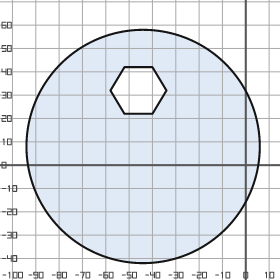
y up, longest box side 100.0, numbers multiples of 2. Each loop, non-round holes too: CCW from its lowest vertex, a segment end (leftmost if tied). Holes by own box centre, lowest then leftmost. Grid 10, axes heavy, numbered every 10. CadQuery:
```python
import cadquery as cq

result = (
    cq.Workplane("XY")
    .moveTo(-44.0, 8.0)
    .circle(50.0)
    .moveTo(-52.0, 22.0)
    .lineTo(-40.0, 22.0)
    .lineTo(-34.0, 32.0)
    .lineTo(-40.0, 42.0)
    .lineTo(-52.0, 42.0)
    .lineTo(-58.0, 32.0)
    .close()
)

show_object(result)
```